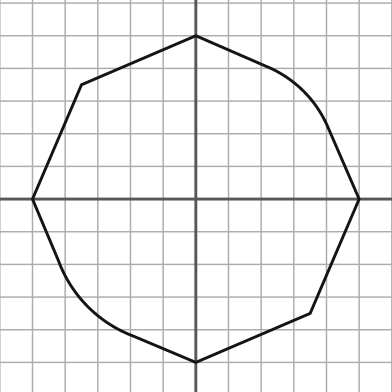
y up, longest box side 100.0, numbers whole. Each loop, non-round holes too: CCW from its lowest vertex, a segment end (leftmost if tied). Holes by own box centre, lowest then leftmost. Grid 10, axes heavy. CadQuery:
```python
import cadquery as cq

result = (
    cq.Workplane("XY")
    .moveTo(0.0, -50.0)
    .lineTo(35.0, -35.0)
    .lineTo(50.0, 0.0)
    .lineTo(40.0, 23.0)
    .threePointArc((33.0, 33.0), (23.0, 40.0))
    .lineTo(0.0, 50.0)
    .lineTo(-35.0, 35.0)
    .lineTo(-50.0, 0.0)
    .lineTo(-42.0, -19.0)
    .threePointArc((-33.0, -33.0), (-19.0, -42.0))
    .close()
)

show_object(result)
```